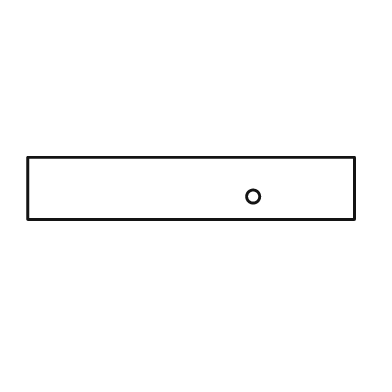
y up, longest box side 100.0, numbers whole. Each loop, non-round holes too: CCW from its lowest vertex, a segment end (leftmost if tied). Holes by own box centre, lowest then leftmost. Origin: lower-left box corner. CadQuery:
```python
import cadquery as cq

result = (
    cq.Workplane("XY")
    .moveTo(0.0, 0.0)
    .lineTo(100.0, 0.0)
    .lineTo(100.0, 19.0)
    .lineTo(0.0, 19.0)
    .close()
    .moveTo(69.0, 7.0)
    .circle(2.0)
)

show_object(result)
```